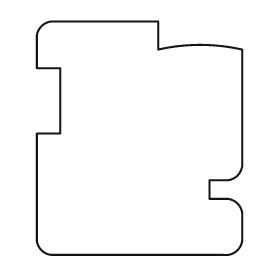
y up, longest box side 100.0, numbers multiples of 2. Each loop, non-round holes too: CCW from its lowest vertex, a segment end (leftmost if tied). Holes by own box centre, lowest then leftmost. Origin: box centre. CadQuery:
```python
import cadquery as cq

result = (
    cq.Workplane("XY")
    .moveTo(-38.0, -50.0)
    .lineTo(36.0, -50.0)
    .threePointArc((42.0, -48.0), (44.0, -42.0))
    .lineTo(44.0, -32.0)
    .threePointArc((42.0, -28.0), (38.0, -26.0))
    .lineTo(30.0, -26.0)
    .lineTo(30.0, -18.0)
    .lineTo(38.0, -18.0)
    .threePointArc((42.0, -16.0), (44.0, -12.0))
    .lineTo(44.0, 38.0)
    .threePointArc((26.0, 40.0), (8.0, 38.0))
    .lineTo(8.0, 50.0)
    .lineTo(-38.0, 50.0)
    .threePointArc((-42.0, 48.0), (-44.0, 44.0))
    .lineTo(-44.0, 30.0)
    .lineTo(-34.0, 30.0)
    .lineTo(-34.0, 2.0)
    .lineTo(-44.0, 2.0)
    .lineTo(-44.0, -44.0)
    .threePointArc((-42.0, -48.0), (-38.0, -50.0))
    .close()
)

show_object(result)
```